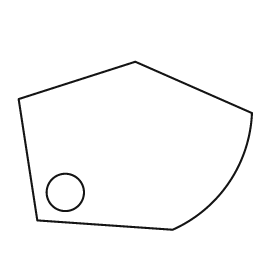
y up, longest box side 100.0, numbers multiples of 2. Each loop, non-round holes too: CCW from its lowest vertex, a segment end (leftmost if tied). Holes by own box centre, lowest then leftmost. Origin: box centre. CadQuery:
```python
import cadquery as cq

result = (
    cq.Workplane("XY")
    .moveTo(16.0, -36.0)
    .threePointArc((40.0, -16.0), (50.0, 14.0))
    .lineTo(0.0, 36.0)
    .lineTo(-50.0, 20.0)
    .lineTo(-42.0, -32.0)
    .close()
    .moveTo(-30.0, -20.0)
    .circle(8.0)
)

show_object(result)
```